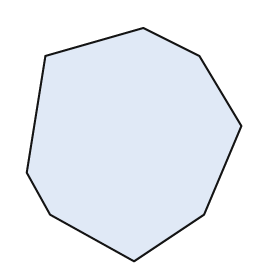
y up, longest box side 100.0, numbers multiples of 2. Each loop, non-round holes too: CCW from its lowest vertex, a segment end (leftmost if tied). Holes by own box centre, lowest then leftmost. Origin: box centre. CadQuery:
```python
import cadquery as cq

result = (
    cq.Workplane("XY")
    .moveTo(0.0, -50.0)
    .lineTo(30.0, -30.0)
    .lineTo(46.0, 8.0)
    .lineTo(28.0, 38.0)
    .lineTo(4.0, 50.0)
    .lineTo(-38.0, 38.0)
    .lineTo(-46.0, -12.0)
    .lineTo(-36.0, -30.0)
    .close()
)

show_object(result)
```